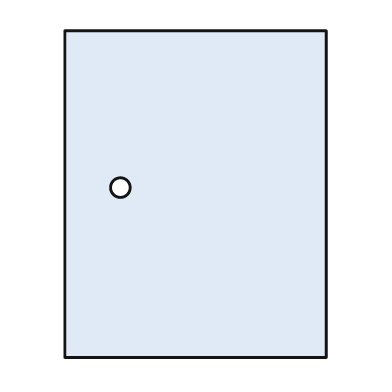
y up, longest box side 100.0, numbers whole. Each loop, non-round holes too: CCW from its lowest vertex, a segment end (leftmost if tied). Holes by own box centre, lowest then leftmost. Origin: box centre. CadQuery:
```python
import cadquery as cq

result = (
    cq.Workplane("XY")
    .moveTo(-40.0, -50.0)
    .lineTo(40.0, -50.0)
    .lineTo(40.0, 50.0)
    .lineTo(-40.0, 50.0)
    .close()
    .moveTo(-23.0, 2.0)
    .circle(3.0)
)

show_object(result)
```